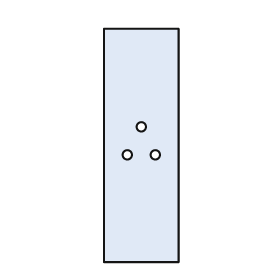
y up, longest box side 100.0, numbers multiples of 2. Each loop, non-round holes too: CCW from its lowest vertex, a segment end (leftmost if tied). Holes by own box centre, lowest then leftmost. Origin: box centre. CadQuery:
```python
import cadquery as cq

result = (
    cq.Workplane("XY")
    .moveTo(-16.0, -50.0)
    .lineTo(16.0, -50.0)
    .lineTo(16.0, 50.0)
    .lineTo(-16.0, 50.0)
    .close()
    .moveTo(-6.0, -4.0)
    .circle(2.0)
    .moveTo(6.0, -4.0)
    .circle(2.0)
    .moveTo(0.0, 8.0)
    .circle(2.0)
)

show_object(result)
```